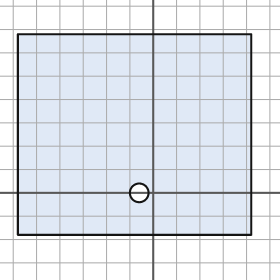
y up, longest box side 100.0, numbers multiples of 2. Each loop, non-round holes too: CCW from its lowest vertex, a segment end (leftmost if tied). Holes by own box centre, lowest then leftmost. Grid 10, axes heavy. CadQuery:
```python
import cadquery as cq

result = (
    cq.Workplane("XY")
    .moveTo(-58.0, -18.0)
    .lineTo(42.0, -18.0)
    .lineTo(42.0, 68.0)
    .lineTo(-58.0, 68.0)
    .close()
    .moveTo(-6.0, 0.0)
    .circle(4.0)
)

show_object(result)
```